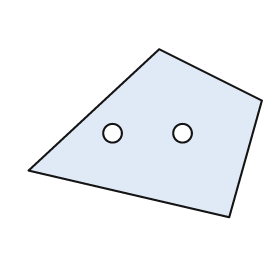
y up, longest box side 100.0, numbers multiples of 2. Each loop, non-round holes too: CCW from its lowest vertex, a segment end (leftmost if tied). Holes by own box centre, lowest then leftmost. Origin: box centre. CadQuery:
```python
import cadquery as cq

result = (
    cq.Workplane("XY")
    .moveTo(36.0, -36.0)
    .lineTo(50.0, 14.0)
    .lineTo(6.0, 36.0)
    .lineTo(-50.0, -16.0)
    .close()
    .moveTo(-14.0, 0.0)
    .circle(4.0)
    .moveTo(16.0, 0.0)
    .circle(4.0)
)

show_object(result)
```